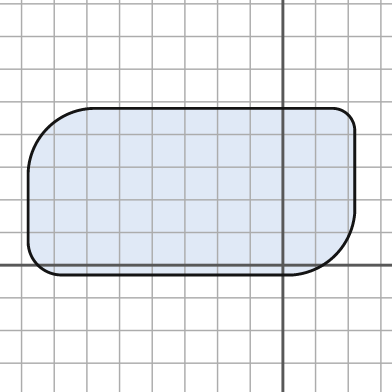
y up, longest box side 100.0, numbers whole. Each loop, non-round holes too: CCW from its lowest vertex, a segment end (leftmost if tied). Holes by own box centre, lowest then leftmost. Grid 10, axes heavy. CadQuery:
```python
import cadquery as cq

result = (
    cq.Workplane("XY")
    .moveTo(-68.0, -3.0)
    .lineTo(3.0, -3.0)
    .threePointArc((16.0, 3.0), (22.0, 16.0))
    .lineTo(22.0, 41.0)
    .threePointArc((20.0, 46.0), (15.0, 48.0))
    .lineTo(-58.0, 48.0)
    .threePointArc((-72.0, 42.0), (-78.0, 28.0))
    .lineTo(-78.0, 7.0)
    .threePointArc((-75.0, 0.0), (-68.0, -3.0))
    .close()
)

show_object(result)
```